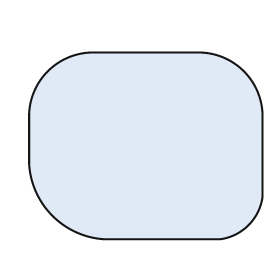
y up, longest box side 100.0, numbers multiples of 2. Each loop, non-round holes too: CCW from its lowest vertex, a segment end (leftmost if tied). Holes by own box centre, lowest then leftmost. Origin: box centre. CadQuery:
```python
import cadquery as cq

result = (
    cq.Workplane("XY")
    .moveTo(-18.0, -40.0)
    .lineTo(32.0, -40.0)
    .threePointArc((44.0, -34.0), (50.0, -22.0))
    .lineTo(50.0, 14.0)
    .threePointArc((42.0, 32.0), (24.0, 40.0))
    .lineTo(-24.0, 40.0)
    .threePointArc((-42.0, 32.0), (-50.0, 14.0))
    .lineTo(-50.0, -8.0)
    .threePointArc((-40.0, -30.0), (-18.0, -40.0))
    .close()
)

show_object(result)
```